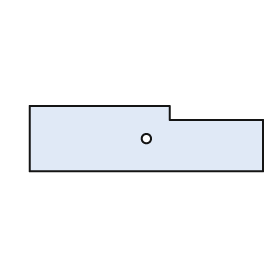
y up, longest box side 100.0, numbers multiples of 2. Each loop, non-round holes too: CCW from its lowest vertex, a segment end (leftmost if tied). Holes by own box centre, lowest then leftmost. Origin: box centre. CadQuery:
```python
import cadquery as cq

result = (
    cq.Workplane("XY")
    .moveTo(-50.0, -14.0)
    .lineTo(50.0, -14.0)
    .lineTo(50.0, 8.0)
    .lineTo(10.0, 8.0)
    .lineTo(10.0, 14.0)
    .lineTo(-50.0, 14.0)
    .close()
    .moveTo(0.0, 0.0)
    .circle(2.0)
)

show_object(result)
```